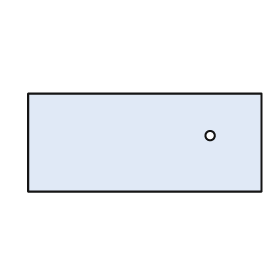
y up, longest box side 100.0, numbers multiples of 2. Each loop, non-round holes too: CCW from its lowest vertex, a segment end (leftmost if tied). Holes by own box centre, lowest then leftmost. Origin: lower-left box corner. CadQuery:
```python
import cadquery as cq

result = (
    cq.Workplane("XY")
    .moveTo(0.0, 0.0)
    .lineTo(100.0, 0.0)
    .lineTo(100.0, 42.0)
    .lineTo(0.0, 42.0)
    .close()
    .moveTo(78.0, 24.0)
    .circle(2.0)
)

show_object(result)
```